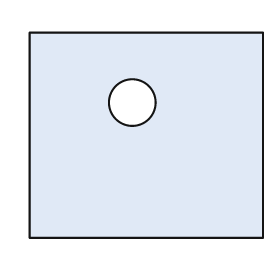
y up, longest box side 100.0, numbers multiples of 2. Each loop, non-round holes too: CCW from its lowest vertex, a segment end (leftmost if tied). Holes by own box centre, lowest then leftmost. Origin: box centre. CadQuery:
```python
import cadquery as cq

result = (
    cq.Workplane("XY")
    .moveTo(-50.0, -44.0)
    .lineTo(50.0, -44.0)
    .lineTo(50.0, 44.0)
    .lineTo(-50.0, 44.0)
    .close()
    .moveTo(-6.0, 14.0)
    .circle(10.0)
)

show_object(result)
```